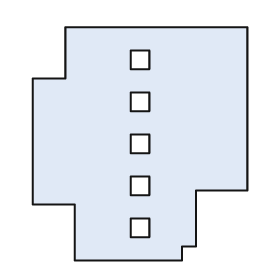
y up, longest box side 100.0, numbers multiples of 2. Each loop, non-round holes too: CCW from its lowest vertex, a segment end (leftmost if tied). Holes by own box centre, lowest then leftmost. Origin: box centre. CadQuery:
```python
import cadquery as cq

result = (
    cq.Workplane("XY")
    .moveTo(-28.0, -50.0)
    .lineTo(18.0, -50.0)
    .lineTo(18.0, -44.0)
    .lineTo(24.0, -44.0)
    .lineTo(24.0, -20.0)
    .lineTo(46.0, -20.0)
    .lineTo(46.0, 50.0)
    .lineTo(-32.0, 50.0)
    .lineTo(-32.0, 28.0)
    .lineTo(-46.0, 28.0)
    .lineTo(-46.0, -26.0)
    .lineTo(-28.0, -26.0)
    .close()
    .moveTo(-4.0, -40.0)
    .lineTo(4.0, -40.0)
    .lineTo(4.0, -32.0)
    .lineTo(-4.0, -32.0)
    .close()
    .moveTo(-4.0, -22.0)
    .lineTo(4.0, -22.0)
    .lineTo(4.0, -14.0)
    .lineTo(-4.0, -14.0)
    .close()
    .moveTo(-4.0, -4.0)
    .lineTo(4.0, -4.0)
    .lineTo(4.0, 4.0)
    .lineTo(-4.0, 4.0)
    .close()
    .moveTo(-4.0, 14.0)
    .lineTo(4.0, 14.0)
    .lineTo(4.0, 22.0)
    .lineTo(-4.0, 22.0)
    .close()
    .moveTo(-4.0, 32.0)
    .lineTo(4.0, 32.0)
    .lineTo(4.0, 40.0)
    .lineTo(-4.0, 40.0)
    .close()
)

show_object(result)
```